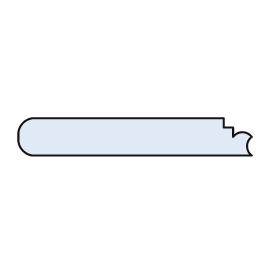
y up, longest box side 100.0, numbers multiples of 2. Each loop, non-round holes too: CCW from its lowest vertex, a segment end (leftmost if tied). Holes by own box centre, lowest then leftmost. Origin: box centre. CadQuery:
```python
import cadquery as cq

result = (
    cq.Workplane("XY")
    .moveTo(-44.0, -8.0)
    .lineTo(50.0, -8.0)
    .threePointArc((48.0, -4.0), (50.0, 0.0))
    .threePointArc((46.0, 2.0), (42.0, 0.0))
    .lineTo(42.0, 4.0)
    .lineTo(38.0, 4.0)
    .lineTo(38.0, 8.0)
    .lineTo(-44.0, 8.0)
    .threePointArc((-48.0, 6.0), (-50.0, 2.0))
    .lineTo(-50.0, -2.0)
    .threePointArc((-48.0, -6.0), (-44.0, -8.0))
    .close()
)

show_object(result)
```